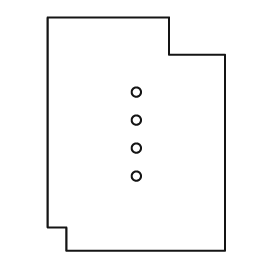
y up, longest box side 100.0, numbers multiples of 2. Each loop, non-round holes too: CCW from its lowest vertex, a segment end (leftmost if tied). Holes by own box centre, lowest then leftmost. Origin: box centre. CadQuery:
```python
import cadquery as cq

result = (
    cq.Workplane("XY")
    .moveTo(-30.0, -50.0)
    .lineTo(38.0, -50.0)
    .lineTo(38.0, 34.0)
    .lineTo(14.0, 34.0)
    .lineTo(14.0, 50.0)
    .lineTo(-38.0, 50.0)
    .lineTo(-38.0, -40.0)
    .lineTo(-30.0, -40.0)
    .close()
    .moveTo(0.0, -18.0)
    .circle(2.0)
    .moveTo(0.0, -6.0)
    .circle(2.0)
    .moveTo(0.0, 6.0)
    .circle(2.0)
    .moveTo(0.0, 18.0)
    .circle(2.0)
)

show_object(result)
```